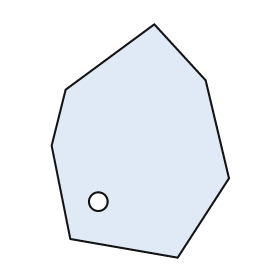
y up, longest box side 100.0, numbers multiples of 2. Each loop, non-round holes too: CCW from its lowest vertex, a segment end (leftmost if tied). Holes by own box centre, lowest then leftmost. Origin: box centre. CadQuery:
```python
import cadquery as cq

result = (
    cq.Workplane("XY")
    .moveTo(16.0, -50.0)
    .lineTo(38.0, -16.0)
    .lineTo(28.0, 26.0)
    .lineTo(6.0, 50.0)
    .lineTo(-32.0, 22.0)
    .lineTo(-38.0, -2.0)
    .lineTo(-30.0, -42.0)
    .close()
    .moveTo(-18.0, -26.0)
    .circle(4.0)
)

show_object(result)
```